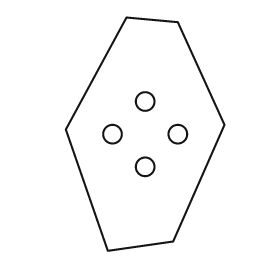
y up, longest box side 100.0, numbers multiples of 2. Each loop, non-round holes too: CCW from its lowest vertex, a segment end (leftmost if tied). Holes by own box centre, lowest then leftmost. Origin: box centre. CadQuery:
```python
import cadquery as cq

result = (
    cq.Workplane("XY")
    .moveTo(-16.0, -50.0)
    .lineTo(12.0, -46.0)
    .lineTo(34.0, 4.0)
    .lineTo(14.0, 48.0)
    .lineTo(-8.0, 50.0)
    .lineTo(-34.0, 2.0)
    .close()
    .moveTo(0.0, -14.0)
    .circle(4.0)
    .moveTo(-14.0, 0.0)
    .circle(4.0)
    .moveTo(14.0, 0.0)
    .circle(4.0)
    .moveTo(0.0, 14.0)
    .circle(4.0)
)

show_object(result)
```